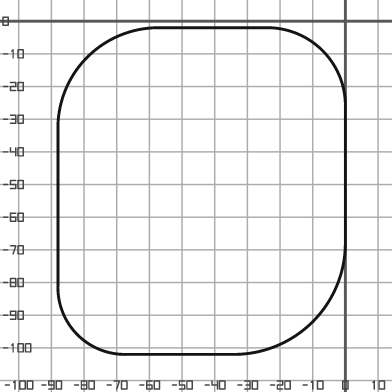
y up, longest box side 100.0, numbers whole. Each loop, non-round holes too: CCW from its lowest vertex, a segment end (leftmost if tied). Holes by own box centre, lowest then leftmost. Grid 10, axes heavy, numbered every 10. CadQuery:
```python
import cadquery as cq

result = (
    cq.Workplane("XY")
    .moveTo(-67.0, -102.0)
    .lineTo(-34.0, -102.0)
    .threePointArc((-10.0, -92.0), (0.0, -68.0))
    .lineTo(0.0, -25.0)
    .threePointArc((-7.0, -9.0), (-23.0, -2.0))
    .lineTo(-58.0, -2.0)
    .threePointArc((-79.0, -11.0), (-88.0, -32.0))
    .lineTo(-88.0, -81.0)
    .threePointArc((-82.0, -96.0), (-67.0, -102.0))
    .close()
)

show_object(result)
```